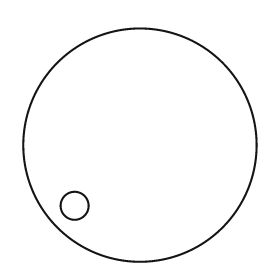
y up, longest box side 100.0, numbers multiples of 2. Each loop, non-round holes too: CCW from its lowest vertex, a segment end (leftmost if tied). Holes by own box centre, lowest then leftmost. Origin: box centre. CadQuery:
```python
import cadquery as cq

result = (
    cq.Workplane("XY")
    .moveTo(0.0, 0.0)
    .circle(50.0)
    .moveTo(-28.0, -26.0)
    .circle(6.0)
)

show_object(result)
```